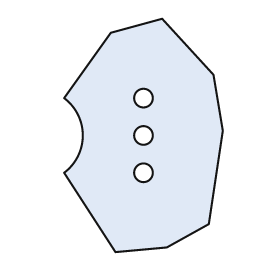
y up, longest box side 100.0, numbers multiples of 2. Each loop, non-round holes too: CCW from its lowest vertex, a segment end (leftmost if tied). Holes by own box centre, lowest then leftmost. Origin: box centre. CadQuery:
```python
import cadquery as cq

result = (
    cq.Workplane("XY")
    .moveTo(-12.0, -50.0)
    .lineTo(10.0, -48.0)
    .lineTo(28.0, -38.0)
    .lineTo(34.0, 2.0)
    .lineTo(30.0, 26.0)
    .lineTo(8.0, 50.0)
    .lineTo(-14.0, 44.0)
    .lineTo(-34.0, 16.0)
    .threePointArc((-26.0, 0.0), (-34.0, -16.0))
    .close()
    .moveTo(0.0, -16.0)
    .circle(4.0)
    .moveTo(0.0, 0.0)
    .circle(4.0)
    .moveTo(0.0, 16.0)
    .circle(4.0)
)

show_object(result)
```